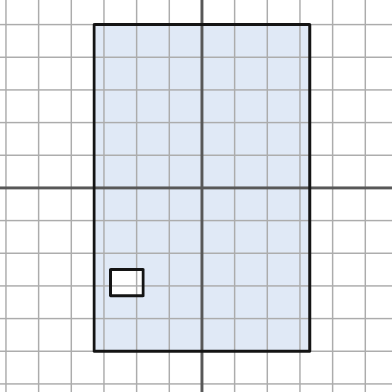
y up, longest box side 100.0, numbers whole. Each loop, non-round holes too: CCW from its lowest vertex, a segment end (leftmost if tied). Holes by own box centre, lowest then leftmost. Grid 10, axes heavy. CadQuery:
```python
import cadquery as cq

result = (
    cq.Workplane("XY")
    .moveTo(-33.0, -50.0)
    .lineTo(33.0, -50.0)
    .lineTo(33.0, 50.0)
    .lineTo(-33.0, 50.0)
    .close()
    .moveTo(-28.0, -33.0)
    .lineTo(-18.0, -33.0)
    .lineTo(-18.0, -25.0)
    .lineTo(-28.0, -25.0)
    .close()
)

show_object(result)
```